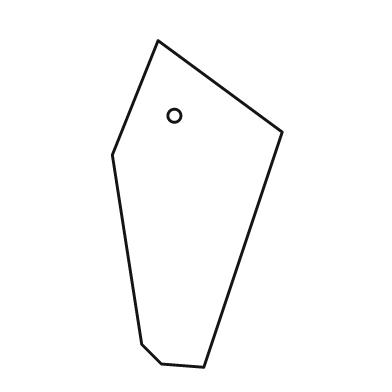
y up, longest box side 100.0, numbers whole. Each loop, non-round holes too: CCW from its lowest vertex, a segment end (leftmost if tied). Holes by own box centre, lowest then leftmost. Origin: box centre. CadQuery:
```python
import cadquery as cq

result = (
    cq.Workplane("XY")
    .moveTo(2.0, -50.0)
    .lineTo(26.0, 22.0)
    .lineTo(-12.0, 50.0)
    .lineTo(-26.0, 15.0)
    .lineTo(-17.0, -43.0)
    .lineTo(-11.0, -49.0)
    .close()
    .moveTo(-7.0, 27.0)
    .circle(2.0)
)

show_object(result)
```